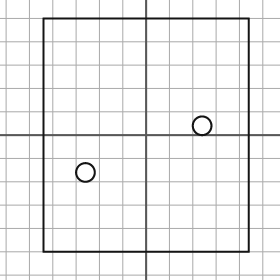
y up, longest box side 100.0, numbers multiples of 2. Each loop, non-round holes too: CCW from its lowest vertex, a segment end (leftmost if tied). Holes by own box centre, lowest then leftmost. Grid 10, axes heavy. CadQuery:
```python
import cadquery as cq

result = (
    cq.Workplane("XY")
    .moveTo(-44.0, -50.0)
    .lineTo(44.0, -50.0)
    .lineTo(44.0, 50.0)
    .lineTo(-44.0, 50.0)
    .close()
    .moveTo(-26.0, -16.0)
    .circle(4.0)
    .moveTo(24.0, 4.0)
    .circle(4.0)
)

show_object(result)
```